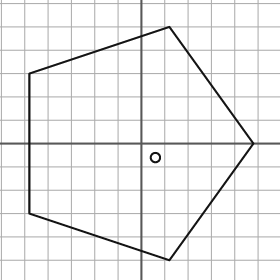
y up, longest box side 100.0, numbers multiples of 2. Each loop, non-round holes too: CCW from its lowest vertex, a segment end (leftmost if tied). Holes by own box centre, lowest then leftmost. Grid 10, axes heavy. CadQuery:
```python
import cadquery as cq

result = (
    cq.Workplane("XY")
    .moveTo(12.0, -50.0)
    .lineTo(48.0, 0.0)
    .lineTo(12.0, 50.0)
    .lineTo(-48.0, 30.0)
    .lineTo(-48.0, -30.0)
    .close()
    .moveTo(6.0, -6.0)
    .circle(2.0)
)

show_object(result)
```